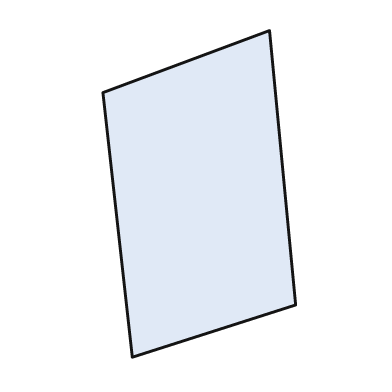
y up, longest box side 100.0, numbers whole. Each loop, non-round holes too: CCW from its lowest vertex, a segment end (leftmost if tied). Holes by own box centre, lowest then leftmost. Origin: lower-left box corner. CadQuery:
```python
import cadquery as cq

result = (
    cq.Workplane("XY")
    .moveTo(9.0, 0.0)
    .lineTo(59.0, 16.0)
    .lineTo(51.0, 100.0)
    .lineTo(0.0, 81.0)
    .close()
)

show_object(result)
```